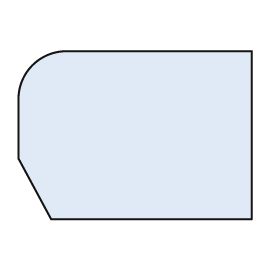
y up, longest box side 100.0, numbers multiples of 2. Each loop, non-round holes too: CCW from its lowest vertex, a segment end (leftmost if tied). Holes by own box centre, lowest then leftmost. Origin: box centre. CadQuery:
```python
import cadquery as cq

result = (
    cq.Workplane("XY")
    .moveTo(-36.0, -36.0)
    .lineTo(50.0, -36.0)
    .lineTo(50.0, 36.0)
    .lineTo(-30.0, 36.0)
    .threePointArc((-44.0, 30.0), (-50.0, 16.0))
    .lineTo(-50.0, -10.0)
    .close()
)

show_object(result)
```